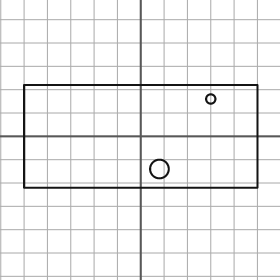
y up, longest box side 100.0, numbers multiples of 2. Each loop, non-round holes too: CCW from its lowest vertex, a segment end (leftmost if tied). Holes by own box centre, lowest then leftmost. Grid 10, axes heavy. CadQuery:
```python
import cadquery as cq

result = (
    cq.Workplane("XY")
    .moveTo(-50.0, -22.0)
    .lineTo(50.0, -22.0)
    .lineTo(50.0, 22.0)
    .lineTo(-50.0, 22.0)
    .close()
    .moveTo(8.0, -14.0)
    .circle(4.0)
    .moveTo(30.0, 16.0)
    .circle(2.0)
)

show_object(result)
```